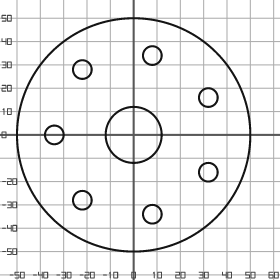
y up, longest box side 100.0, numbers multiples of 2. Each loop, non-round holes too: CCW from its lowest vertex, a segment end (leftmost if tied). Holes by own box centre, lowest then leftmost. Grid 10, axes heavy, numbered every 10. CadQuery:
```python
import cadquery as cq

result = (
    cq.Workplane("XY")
    .moveTo(0.0, 0.0)
    .circle(50.0)
    .moveTo(8.0, -34.0)
    .circle(4.0)
    .moveTo(-22.0, -28.0)
    .circle(4.0)
    .moveTo(32.0, -16.0)
    .circle(4.0)
    .moveTo(-34.0, 0.0)
    .circle(4.0)
    .moveTo(0.0, 0.0)
    .circle(12.0)
    .moveTo(32.0, 16.0)
    .circle(4.0)
    .moveTo(-22.0, 28.0)
    .circle(4.0)
    .moveTo(8.0, 34.0)
    .circle(4.0)
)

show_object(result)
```